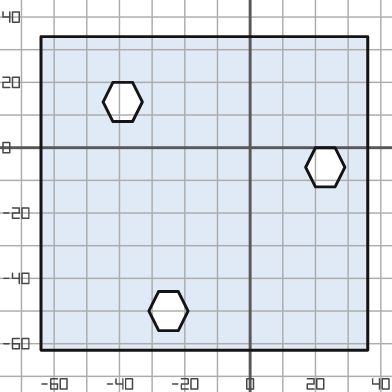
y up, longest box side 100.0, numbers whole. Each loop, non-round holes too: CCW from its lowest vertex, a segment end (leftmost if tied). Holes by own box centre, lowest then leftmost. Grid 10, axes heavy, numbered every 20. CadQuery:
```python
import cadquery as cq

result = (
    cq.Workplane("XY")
    .moveTo(-64.0, -62.0)
    .lineTo(36.0, -62.0)
    .lineTo(36.0, 34.0)
    .lineTo(-64.0, 34.0)
    .close()
    .moveTo(-28.0, -56.0)
    .lineTo(-22.0, -56.0)
    .lineTo(-19.0, -50.0)
    .lineTo(-22.0, -44.0)
    .lineTo(-28.0, -44.0)
    .lineTo(-31.0, -50.0)
    .close()
    .moveTo(20.0, -12.0)
    .lineTo(26.0, -12.0)
    .lineTo(29.0, -6.0)
    .lineTo(26.0, 0.0)
    .lineTo(20.0, 0.0)
    .lineTo(17.0, -6.0)
    .close()
    .moveTo(-42.0, 8.0)
    .lineTo(-36.0, 8.0)
    .lineTo(-33.0, 14.0)
    .lineTo(-36.0, 20.0)
    .lineTo(-42.0, 20.0)
    .lineTo(-45.0, 14.0)
    .close()
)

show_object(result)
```